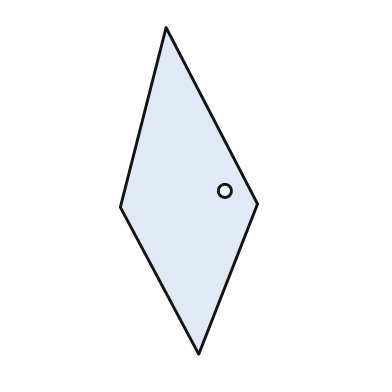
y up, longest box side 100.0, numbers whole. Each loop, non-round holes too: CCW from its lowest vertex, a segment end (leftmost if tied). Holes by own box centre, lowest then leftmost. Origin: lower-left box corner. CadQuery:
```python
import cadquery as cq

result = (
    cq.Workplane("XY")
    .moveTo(24.0, 0.0)
    .lineTo(42.0, 46.0)
    .lineTo(14.0, 100.0)
    .lineTo(0.0, 45.0)
    .close()
    .moveTo(32.0, 50.0)
    .circle(2.0)
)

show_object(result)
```